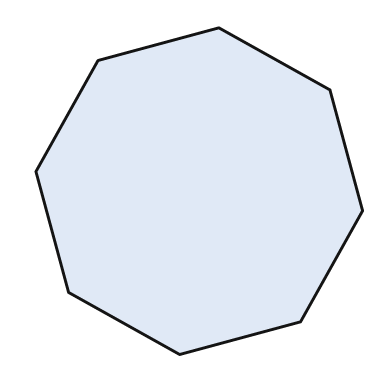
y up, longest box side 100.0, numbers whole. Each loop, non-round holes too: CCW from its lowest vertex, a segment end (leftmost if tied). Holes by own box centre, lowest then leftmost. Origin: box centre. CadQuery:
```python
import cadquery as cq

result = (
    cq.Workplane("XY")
    .moveTo(-6.0, -50.0)
    .lineTo(31.0, -40.0)
    .lineTo(50.0, -6.0)
    .lineTo(40.0, 31.0)
    .lineTo(6.0, 50.0)
    .lineTo(-31.0, 40.0)
    .lineTo(-50.0, 6.0)
    .lineTo(-40.0, -31.0)
    .close()
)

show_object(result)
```